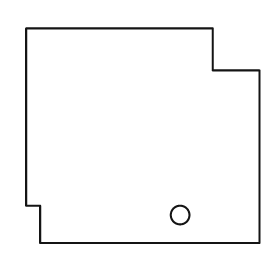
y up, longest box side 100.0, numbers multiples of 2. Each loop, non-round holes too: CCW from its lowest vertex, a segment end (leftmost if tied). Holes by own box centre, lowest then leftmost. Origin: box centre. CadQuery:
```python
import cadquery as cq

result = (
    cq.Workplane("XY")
    .moveTo(-44.0, -46.0)
    .lineTo(50.0, -46.0)
    .lineTo(50.0, 28.0)
    .lineTo(30.0, 28.0)
    .lineTo(30.0, 46.0)
    .lineTo(-50.0, 46.0)
    .lineTo(-50.0, -30.0)
    .lineTo(-44.0, -30.0)
    .close()
    .moveTo(16.0, -34.0)
    .circle(4.0)
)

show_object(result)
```